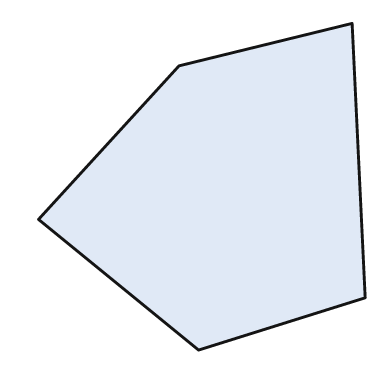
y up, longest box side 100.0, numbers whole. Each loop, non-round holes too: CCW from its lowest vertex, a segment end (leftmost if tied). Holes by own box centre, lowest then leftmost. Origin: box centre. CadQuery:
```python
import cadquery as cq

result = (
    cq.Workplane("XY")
    .moveTo(-1.0, -50.0)
    .lineTo(50.0, -34.0)
    .lineTo(46.0, 50.0)
    .lineTo(-7.0, 37.0)
    .lineTo(-50.0, -10.0)
    .close()
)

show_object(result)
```